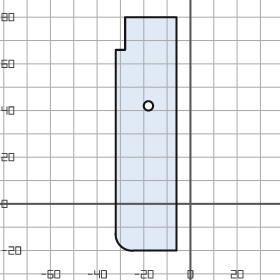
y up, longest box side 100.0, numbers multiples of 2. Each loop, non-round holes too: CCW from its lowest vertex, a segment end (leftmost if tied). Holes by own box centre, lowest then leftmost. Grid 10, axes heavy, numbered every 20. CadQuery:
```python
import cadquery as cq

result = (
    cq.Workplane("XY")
    .moveTo(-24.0, -20.0)
    .lineTo(-6.0, -20.0)
    .lineTo(-6.0, 80.0)
    .lineTo(-28.0, 80.0)
    .lineTo(-28.0, 66.0)
    .lineTo(-32.0, 66.0)
    .lineTo(-32.0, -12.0)
    .threePointArc((-30.0, -18.0), (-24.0, -20.0))
    .close()
    .moveTo(-18.0, 42.0)
    .circle(2.0)
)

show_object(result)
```